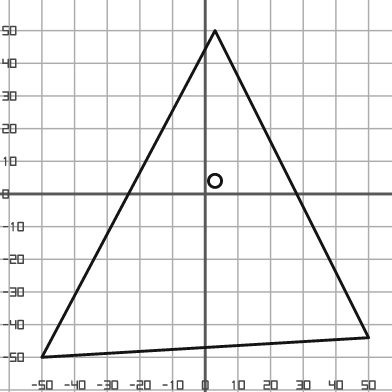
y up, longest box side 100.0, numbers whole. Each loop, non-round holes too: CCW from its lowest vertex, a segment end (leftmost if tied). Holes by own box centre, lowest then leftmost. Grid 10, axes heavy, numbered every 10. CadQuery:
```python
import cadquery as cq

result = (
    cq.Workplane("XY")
    .moveTo(-50.0, -50.0)
    .lineTo(50.0, -44.0)
    .lineTo(3.0, 50.0)
    .close()
    .moveTo(3.0, 4.0)
    .circle(2.0)
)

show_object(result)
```